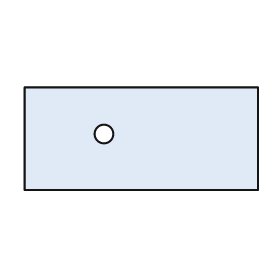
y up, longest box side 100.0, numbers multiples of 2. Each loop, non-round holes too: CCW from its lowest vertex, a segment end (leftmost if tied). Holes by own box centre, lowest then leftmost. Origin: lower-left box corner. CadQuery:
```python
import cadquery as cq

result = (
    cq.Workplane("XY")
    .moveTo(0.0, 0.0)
    .lineTo(100.0, 0.0)
    .lineTo(100.0, 44.0)
    .lineTo(0.0, 44.0)
    .close()
    .moveTo(34.0, 24.0)
    .circle(4.0)
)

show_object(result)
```